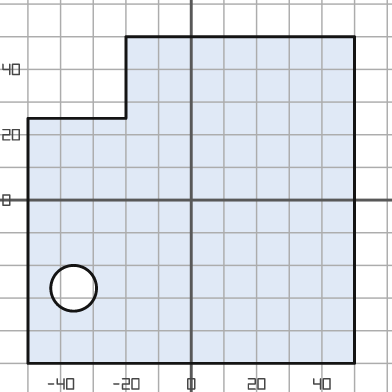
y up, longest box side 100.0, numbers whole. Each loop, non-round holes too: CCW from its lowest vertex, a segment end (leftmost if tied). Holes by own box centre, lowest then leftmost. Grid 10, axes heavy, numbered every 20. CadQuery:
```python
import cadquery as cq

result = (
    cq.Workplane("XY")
    .moveTo(-50.0, -50.0)
    .lineTo(50.0, -50.0)
    .lineTo(50.0, 50.0)
    .lineTo(-20.0, 50.0)
    .lineTo(-20.0, 25.0)
    .lineTo(-50.0, 25.0)
    .close()
    .moveTo(-36.0, -27.0)
    .circle(7.0)
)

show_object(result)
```